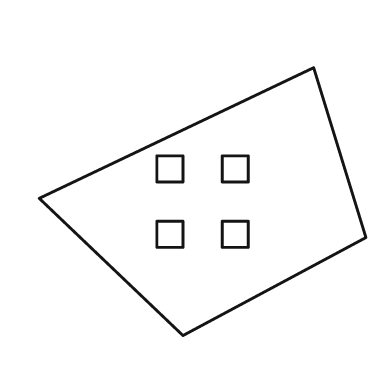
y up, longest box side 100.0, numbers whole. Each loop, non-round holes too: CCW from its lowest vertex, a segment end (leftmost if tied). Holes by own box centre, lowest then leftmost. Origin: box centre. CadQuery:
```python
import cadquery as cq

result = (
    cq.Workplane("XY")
    .moveTo(-6.0, -41.0)
    .lineTo(50.0, -11.0)
    .lineTo(34.0, 41.0)
    .lineTo(-50.0, 1.0)
    .close()
    .moveTo(-14.0, -14.0)
    .lineTo(-6.0, -14.0)
    .lineTo(-6.0, -6.0)
    .lineTo(-14.0, -6.0)
    .close()
    .moveTo(6.0, -14.0)
    .lineTo(14.0, -14.0)
    .lineTo(14.0, -6.0)
    .lineTo(6.0, -6.0)
    .close()
    .moveTo(-14.0, 6.0)
    .lineTo(-6.0, 6.0)
    .lineTo(-6.0, 14.0)
    .lineTo(-14.0, 14.0)
    .close()
    .moveTo(6.0, 6.0)
    .lineTo(14.0, 6.0)
    .lineTo(14.0, 14.0)
    .lineTo(6.0, 14.0)
    .close()
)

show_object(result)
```